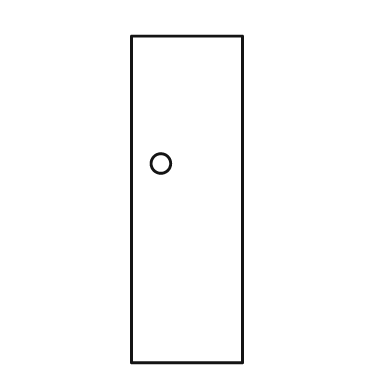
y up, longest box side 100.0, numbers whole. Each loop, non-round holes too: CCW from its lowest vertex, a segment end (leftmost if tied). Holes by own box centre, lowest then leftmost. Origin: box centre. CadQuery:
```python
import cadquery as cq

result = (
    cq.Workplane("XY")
    .moveTo(-17.0, -50.0)
    .lineTo(17.0, -50.0)
    .lineTo(17.0, 50.0)
    .lineTo(-17.0, 50.0)
    .close()
    .moveTo(-8.0, 11.0)
    .circle(3.0)
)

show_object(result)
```